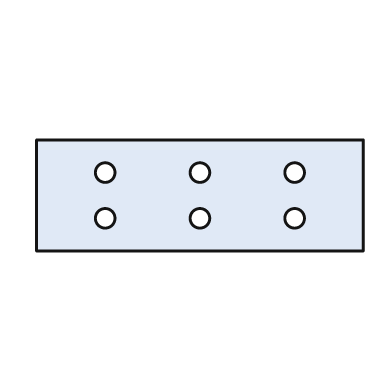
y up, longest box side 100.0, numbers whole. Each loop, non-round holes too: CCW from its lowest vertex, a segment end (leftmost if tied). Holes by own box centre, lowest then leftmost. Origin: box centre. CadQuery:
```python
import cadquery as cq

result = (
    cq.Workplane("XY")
    .moveTo(-50.0, -17.0)
    .lineTo(50.0, -17.0)
    .lineTo(50.0, 17.0)
    .lineTo(-50.0, 17.0)
    .close()
    .moveTo(-29.0, -7.0)
    .circle(3.0)
    .moveTo(0.0, -7.0)
    .circle(3.0)
    .moveTo(29.0, -7.0)
    .circle(3.0)
    .moveTo(-29.0, 7.0)
    .circle(3.0)
    .moveTo(0.0, 7.0)
    .circle(3.0)
    .moveTo(29.0, 7.0)
    .circle(3.0)
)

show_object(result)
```